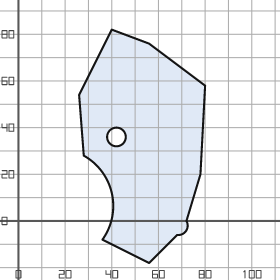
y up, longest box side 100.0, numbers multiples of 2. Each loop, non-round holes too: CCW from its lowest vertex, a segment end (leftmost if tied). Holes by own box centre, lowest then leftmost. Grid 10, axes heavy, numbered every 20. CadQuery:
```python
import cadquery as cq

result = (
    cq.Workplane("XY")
    .moveTo(56.0, -18.0)
    .lineTo(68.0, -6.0)
    .threePointArc((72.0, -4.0), (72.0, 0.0))
    .lineTo(78.0, 20.0)
    .lineTo(80.0, 58.0)
    .lineTo(56.0, 76.0)
    .lineTo(40.0, 82.0)
    .lineTo(26.0, 54.0)
    .lineTo(28.0, 28.0)
    .threePointArc((40.0, 12.0), (36.0, -8.0))
    .close()
    .moveTo(42.0, 36.0)
    .circle(4.0)
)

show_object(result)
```